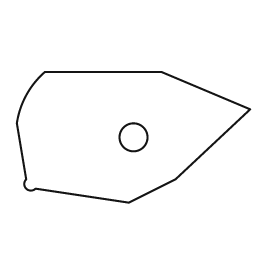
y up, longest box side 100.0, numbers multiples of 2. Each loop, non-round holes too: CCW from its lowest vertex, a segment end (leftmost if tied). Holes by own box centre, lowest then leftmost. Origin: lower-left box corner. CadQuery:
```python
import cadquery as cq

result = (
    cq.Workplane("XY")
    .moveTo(48.0, 0.0)
    .lineTo(68.0, 10.0)
    .lineTo(100.0, 40.0)
    .lineTo(62.0, 56.0)
    .lineTo(12.0, 56.0)
    .threePointArc((4.0, 46.0), (0.0, 34.0))
    .lineTo(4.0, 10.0)
    .threePointArc((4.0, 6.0), (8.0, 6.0))
    .close()
    .moveTo(50.0, 28.0)
    .circle(6.0)
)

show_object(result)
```